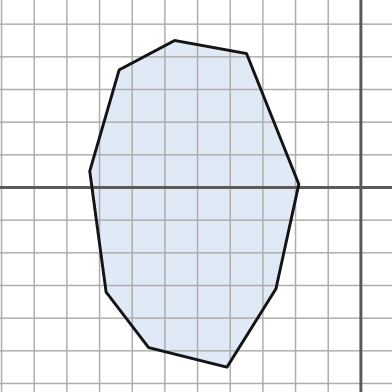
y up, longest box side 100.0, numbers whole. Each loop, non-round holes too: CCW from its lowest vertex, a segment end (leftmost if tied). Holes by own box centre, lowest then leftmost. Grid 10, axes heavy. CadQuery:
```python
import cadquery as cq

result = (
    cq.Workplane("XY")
    .moveTo(-41.0, -55.0)
    .lineTo(-26.0, -31.0)
    .lineTo(-19.0, 1.0)
    .lineTo(-35.0, 41.0)
    .lineTo(-57.0, 45.0)
    .lineTo(-74.0, 36.0)
    .lineTo(-83.0, 5.0)
    .lineTo(-78.0, -32.0)
    .lineTo(-65.0, -49.0)
    .close()
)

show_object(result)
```